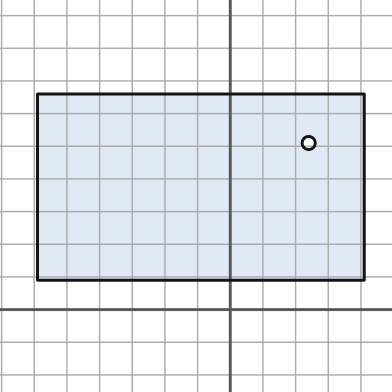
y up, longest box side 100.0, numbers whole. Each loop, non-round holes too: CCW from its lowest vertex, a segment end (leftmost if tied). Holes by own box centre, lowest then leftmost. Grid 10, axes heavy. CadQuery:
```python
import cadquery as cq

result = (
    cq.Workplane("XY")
    .moveTo(-59.0, 9.0)
    .lineTo(41.0, 9.0)
    .lineTo(41.0, 66.0)
    .lineTo(-59.0, 66.0)
    .close()
    .moveTo(24.0, 51.0)
    .circle(2.0)
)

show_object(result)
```